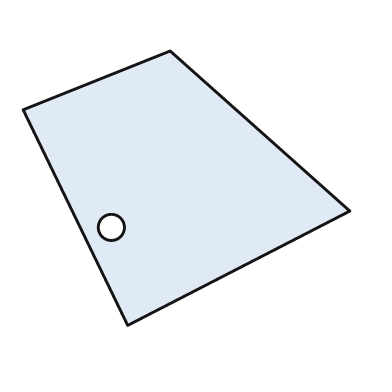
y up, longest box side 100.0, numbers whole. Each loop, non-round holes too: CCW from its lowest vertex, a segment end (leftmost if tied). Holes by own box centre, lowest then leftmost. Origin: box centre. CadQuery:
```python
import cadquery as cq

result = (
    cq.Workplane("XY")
    .moveTo(-18.0, -42.0)
    .lineTo(50.0, -7.0)
    .lineTo(-5.0, 42.0)
    .lineTo(-50.0, 24.0)
    .close()
    .moveTo(-23.0, -12.0)
    .circle(4.0)
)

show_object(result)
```